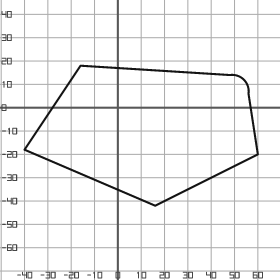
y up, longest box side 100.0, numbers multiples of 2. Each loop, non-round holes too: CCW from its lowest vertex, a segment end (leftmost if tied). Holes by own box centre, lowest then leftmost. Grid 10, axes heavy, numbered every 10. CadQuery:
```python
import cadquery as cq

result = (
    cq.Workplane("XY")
    .moveTo(16.0, -42.0)
    .lineTo(60.0, -20.0)
    .lineTo(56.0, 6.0)
    .threePointArc((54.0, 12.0), (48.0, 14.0))
    .lineTo(-16.0, 18.0)
    .lineTo(-40.0, -18.0)
    .close()
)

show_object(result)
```